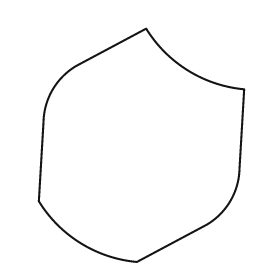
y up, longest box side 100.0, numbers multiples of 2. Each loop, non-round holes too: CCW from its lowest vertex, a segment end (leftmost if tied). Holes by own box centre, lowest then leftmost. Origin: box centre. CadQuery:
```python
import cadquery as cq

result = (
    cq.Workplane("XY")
    .moveTo(-2.0, -50.0)
    .lineTo(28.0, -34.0)
    .threePointArc((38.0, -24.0), (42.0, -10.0))
    .lineTo(44.0, 24.0)
    .threePointArc((20.0, 32.0), (2.0, 50.0))
    .lineTo(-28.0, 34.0)
    .threePointArc((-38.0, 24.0), (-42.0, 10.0))
    .lineTo(-44.0, -24.0)
    .threePointArc((-26.0, -42.0), (-2.0, -50.0))
    .close()
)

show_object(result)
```